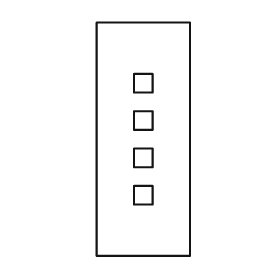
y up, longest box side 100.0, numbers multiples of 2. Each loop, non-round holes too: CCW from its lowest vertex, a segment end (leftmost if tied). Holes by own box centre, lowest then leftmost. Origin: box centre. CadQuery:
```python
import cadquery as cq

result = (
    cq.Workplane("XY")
    .moveTo(-20.0, -50.0)
    .lineTo(20.0, -50.0)
    .lineTo(20.0, 50.0)
    .lineTo(-20.0, 50.0)
    .close()
    .moveTo(-4.0, -28.0)
    .lineTo(4.0, -28.0)
    .lineTo(4.0, -20.0)
    .lineTo(-4.0, -20.0)
    .close()
    .moveTo(-4.0, -12.0)
    .lineTo(4.0, -12.0)
    .lineTo(4.0, -4.0)
    .lineTo(-4.0, -4.0)
    .close()
    .moveTo(-4.0, 4.0)
    .lineTo(4.0, 4.0)
    .lineTo(4.0, 12.0)
    .lineTo(-4.0, 12.0)
    .close()
    .moveTo(-4.0, 20.0)
    .lineTo(4.0, 20.0)
    .lineTo(4.0, 28.0)
    .lineTo(-4.0, 28.0)
    .close()
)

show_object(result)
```